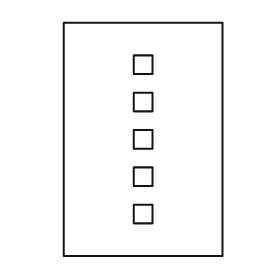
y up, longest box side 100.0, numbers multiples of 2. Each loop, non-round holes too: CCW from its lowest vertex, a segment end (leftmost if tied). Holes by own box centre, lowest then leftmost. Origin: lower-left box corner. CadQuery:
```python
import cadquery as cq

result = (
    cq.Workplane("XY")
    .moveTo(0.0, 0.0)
    .lineTo(68.0, 0.0)
    .lineTo(68.0, 100.0)
    .lineTo(0.0, 100.0)
    .close()
    .moveTo(30.0, 14.0)
    .lineTo(38.0, 14.0)
    .lineTo(38.0, 22.0)
    .lineTo(30.0, 22.0)
    .close()
    .moveTo(30.0, 30.0)
    .lineTo(38.0, 30.0)
    .lineTo(38.0, 38.0)
    .lineTo(30.0, 38.0)
    .close()
    .moveTo(30.0, 46.0)
    .lineTo(38.0, 46.0)
    .lineTo(38.0, 54.0)
    .lineTo(30.0, 54.0)
    .close()
    .moveTo(30.0, 62.0)
    .lineTo(38.0, 62.0)
    .lineTo(38.0, 70.0)
    .lineTo(30.0, 70.0)
    .close()
    .moveTo(30.0, 78.0)
    .lineTo(38.0, 78.0)
    .lineTo(38.0, 86.0)
    .lineTo(30.0, 86.0)
    .close()
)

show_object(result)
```